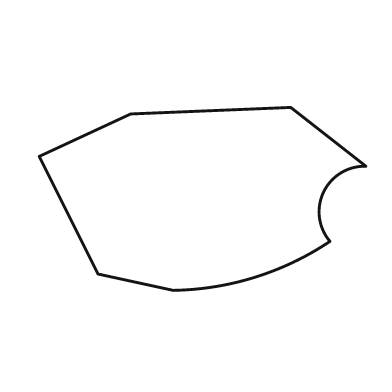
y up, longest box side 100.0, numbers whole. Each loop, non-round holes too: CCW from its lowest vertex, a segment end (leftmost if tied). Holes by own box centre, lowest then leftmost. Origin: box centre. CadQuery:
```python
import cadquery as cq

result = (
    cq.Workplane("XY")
    .moveTo(-9.0, -28.0)
    .threePointArc((16.0, -24.0), (39.0, -13.0))
    .threePointArc((37.0, 2.0), (50.0, 10.0))
    .lineTo(27.0, 28.0)
    .lineTo(-22.0, 26.0)
    .lineTo(-50.0, 13.0)
    .lineTo(-32.0, -23.0)
    .close()
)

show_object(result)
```